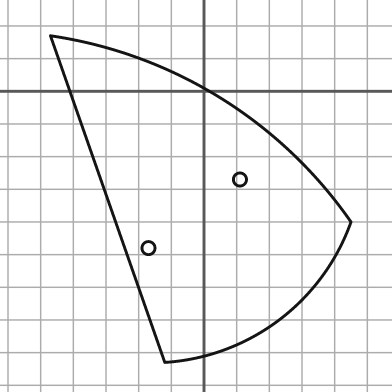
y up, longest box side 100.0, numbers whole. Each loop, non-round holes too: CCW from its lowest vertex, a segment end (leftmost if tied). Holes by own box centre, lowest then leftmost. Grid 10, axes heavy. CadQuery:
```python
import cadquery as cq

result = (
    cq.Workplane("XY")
    .moveTo(-12.0, -83.0)
    .threePointArc((23.0, -70.0), (45.0, -40.0))
    .threePointArc((5.0, -2.0), (-47.0, 17.0))
    .close()
    .moveTo(-17.0, -48.0)
    .circle(2.0)
    .moveTo(11.0, -27.0)
    .circle(2.0)
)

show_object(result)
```